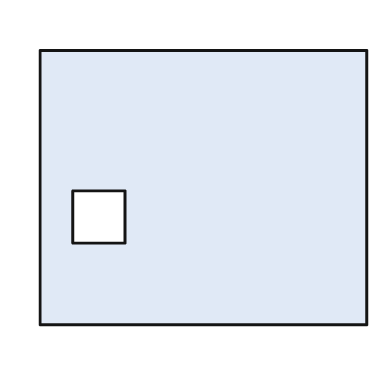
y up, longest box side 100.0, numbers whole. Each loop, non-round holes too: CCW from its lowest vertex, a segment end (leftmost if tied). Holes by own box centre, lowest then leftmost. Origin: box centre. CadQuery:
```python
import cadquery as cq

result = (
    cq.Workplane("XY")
    .moveTo(-50.0, -42.0)
    .lineTo(50.0, -42.0)
    .lineTo(50.0, 42.0)
    .lineTo(-50.0, 42.0)
    .close()
    .moveTo(-40.0, -17.0)
    .lineTo(-24.0, -17.0)
    .lineTo(-24.0, -1.0)
    .lineTo(-40.0, -1.0)
    .close()
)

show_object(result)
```